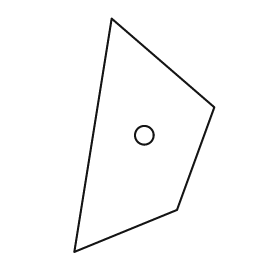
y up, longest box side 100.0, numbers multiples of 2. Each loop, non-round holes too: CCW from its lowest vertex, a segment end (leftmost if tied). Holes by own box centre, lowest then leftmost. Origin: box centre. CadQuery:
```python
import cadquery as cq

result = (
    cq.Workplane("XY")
    .moveTo(-30.0, -50.0)
    .lineTo(14.0, -32.0)
    .lineTo(30.0, 12.0)
    .lineTo(-14.0, 50.0)
    .close()
    .moveTo(0.0, 0.0)
    .circle(4.0)
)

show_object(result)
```